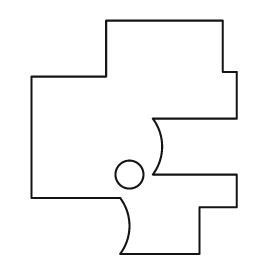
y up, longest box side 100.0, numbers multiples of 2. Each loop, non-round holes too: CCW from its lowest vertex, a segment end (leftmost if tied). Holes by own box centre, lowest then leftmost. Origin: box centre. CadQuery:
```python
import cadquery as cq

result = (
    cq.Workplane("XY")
    .moveTo(-6.0, -50.0)
    .lineTo(28.0, -50.0)
    .lineTo(28.0, -30.0)
    .lineTo(44.0, -30.0)
    .lineTo(44.0, -16.0)
    .lineTo(8.0, -16.0)
    .threePointArc((12.0, -4.0), (8.0, 8.0))
    .lineTo(44.0, 8.0)
    .lineTo(44.0, 28.0)
    .lineTo(38.0, 28.0)
    .lineTo(38.0, 50.0)
    .lineTo(-12.0, 50.0)
    .lineTo(-12.0, 26.0)
    .lineTo(-44.0, 26.0)
    .lineTo(-44.0, -26.0)
    .lineTo(-6.0, -26.0)
    .threePointArc((-2.0, -38.0), (-6.0, -50.0))
    .close()
    .moveTo(-2.0, -16.0)
    .circle(6.0)
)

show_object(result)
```